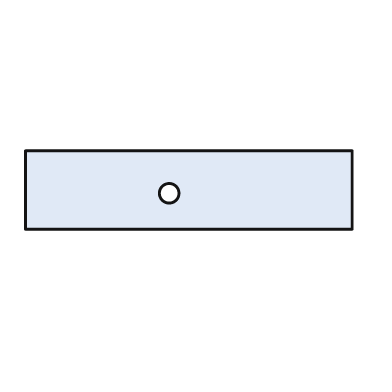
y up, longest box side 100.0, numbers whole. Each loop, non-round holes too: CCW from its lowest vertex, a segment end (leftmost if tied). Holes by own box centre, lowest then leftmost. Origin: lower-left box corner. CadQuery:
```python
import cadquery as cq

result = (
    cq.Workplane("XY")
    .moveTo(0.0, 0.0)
    .lineTo(100.0, 0.0)
    .lineTo(100.0, 24.0)
    .lineTo(0.0, 24.0)
    .close()
    .moveTo(44.0, 11.0)
    .circle(3.0)
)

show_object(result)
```